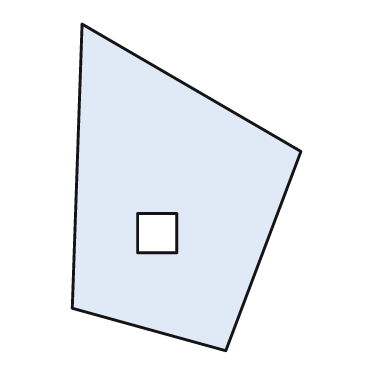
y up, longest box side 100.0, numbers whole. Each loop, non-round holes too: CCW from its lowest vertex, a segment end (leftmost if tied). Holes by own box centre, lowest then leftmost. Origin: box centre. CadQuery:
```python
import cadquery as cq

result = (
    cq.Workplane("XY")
    .moveTo(12.0, -50.0)
    .lineTo(35.0, 11.0)
    .lineTo(-32.0, 50.0)
    .lineTo(-35.0, -37.0)
    .close()
    .moveTo(-15.0, -20.0)
    .lineTo(-3.0, -20.0)
    .lineTo(-3.0, -8.0)
    .lineTo(-15.0, -8.0)
    .close()
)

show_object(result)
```